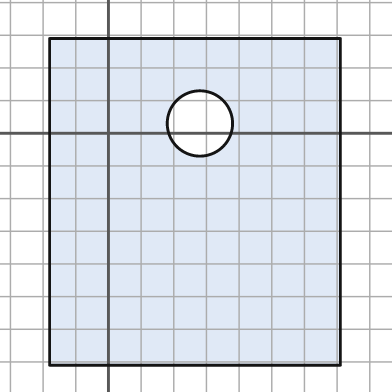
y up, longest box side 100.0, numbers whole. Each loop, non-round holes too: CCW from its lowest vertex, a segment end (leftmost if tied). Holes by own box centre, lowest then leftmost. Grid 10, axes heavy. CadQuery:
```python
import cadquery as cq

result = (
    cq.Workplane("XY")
    .moveTo(-18.0, -71.0)
    .lineTo(71.0, -71.0)
    .lineTo(71.0, 29.0)
    .lineTo(-18.0, 29.0)
    .close()
    .moveTo(28.0, 3.0)
    .circle(10.0)
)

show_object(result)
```